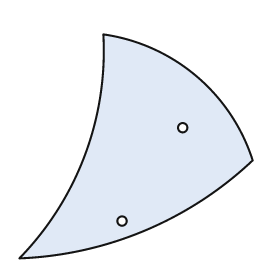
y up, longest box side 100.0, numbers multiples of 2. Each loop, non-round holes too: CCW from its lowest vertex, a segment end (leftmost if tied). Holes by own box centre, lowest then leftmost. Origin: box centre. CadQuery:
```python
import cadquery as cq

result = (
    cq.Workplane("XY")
    .moveTo(-50.0, -48.0)
    .threePointArc((4.0, -36.0), (50.0, -6.0))
    .threePointArc((26.0, 30.0), (-14.0, 48.0))
    .threePointArc((-22.0, -4.0), (-50.0, -48.0))
    .close()
    .moveTo(-6.0, -32.0)
    .circle(2.0)
    .moveTo(20.0, 8.0)
    .circle(2.0)
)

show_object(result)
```